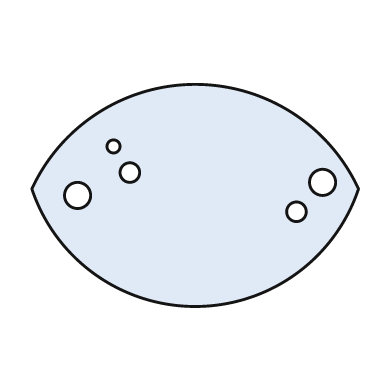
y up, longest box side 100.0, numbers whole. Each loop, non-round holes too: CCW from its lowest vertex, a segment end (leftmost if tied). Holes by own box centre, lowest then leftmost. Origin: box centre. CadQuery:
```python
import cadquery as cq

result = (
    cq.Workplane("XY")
    .moveTo(-50.0, 2.0)
    .threePointArc((0.0, -34.0), (50.0, 2.0))
    .threePointArc((0.0, 34.0), (-50.0, 2.0))
    .close()
    .moveTo(31.0, -5.0)
    .circle(3.0)
    .moveTo(-36.0, 0.0)
    .circle(4.0)
    .moveTo(39.0, 4.0)
    .circle(4.0)
    .moveTo(-20.0, 7.0)
    .circle(3.0)
    .moveTo(-25.0, 15.0)
    .circle(2.0)
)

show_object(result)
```